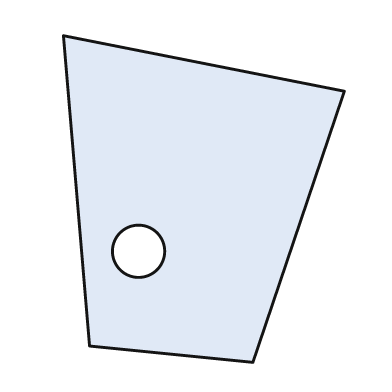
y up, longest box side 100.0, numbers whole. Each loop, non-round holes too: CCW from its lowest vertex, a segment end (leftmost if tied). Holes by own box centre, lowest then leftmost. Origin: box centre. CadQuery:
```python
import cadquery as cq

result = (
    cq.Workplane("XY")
    .moveTo(15.0, -50.0)
    .lineTo(43.0, 33.0)
    .lineTo(-43.0, 50.0)
    .lineTo(-35.0, -45.0)
    .close()
    .moveTo(-20.0, -16.0)
    .circle(8.0)
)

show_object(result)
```